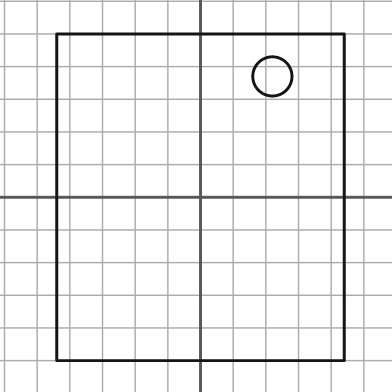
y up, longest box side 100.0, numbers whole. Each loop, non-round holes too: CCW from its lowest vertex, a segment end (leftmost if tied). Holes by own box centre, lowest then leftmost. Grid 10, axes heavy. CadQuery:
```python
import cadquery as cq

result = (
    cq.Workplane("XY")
    .moveTo(-44.0, -50.0)
    .lineTo(44.0, -50.0)
    .lineTo(44.0, 50.0)
    .lineTo(-44.0, 50.0)
    .close()
    .moveTo(22.0, 37.0)
    .circle(6.0)
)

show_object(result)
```